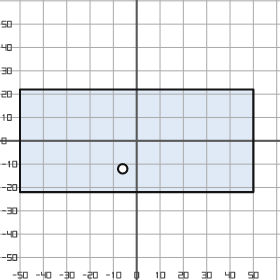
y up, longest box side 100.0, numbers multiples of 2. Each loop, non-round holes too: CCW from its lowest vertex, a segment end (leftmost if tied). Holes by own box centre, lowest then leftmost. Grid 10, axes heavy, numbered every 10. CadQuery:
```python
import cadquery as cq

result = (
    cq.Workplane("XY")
    .moveTo(-50.0, -22.0)
    .lineTo(50.0, -22.0)
    .lineTo(50.0, 22.0)
    .lineTo(-50.0, 22.0)
    .close()
    .moveTo(-6.0, -12.0)
    .circle(2.0)
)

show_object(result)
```